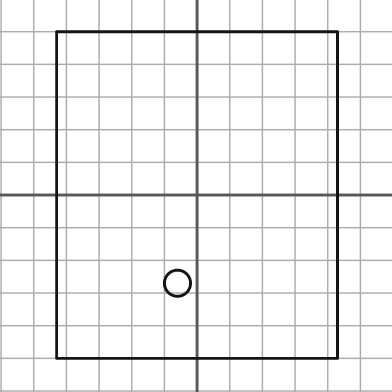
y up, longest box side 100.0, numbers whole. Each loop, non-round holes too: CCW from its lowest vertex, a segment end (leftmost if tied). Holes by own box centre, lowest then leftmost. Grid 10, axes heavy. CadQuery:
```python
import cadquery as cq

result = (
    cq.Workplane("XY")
    .moveTo(-43.0, -50.0)
    .lineTo(43.0, -50.0)
    .lineTo(43.0, 50.0)
    .lineTo(-43.0, 50.0)
    .close()
    .moveTo(-6.0, -27.0)
    .circle(4.0)
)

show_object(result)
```